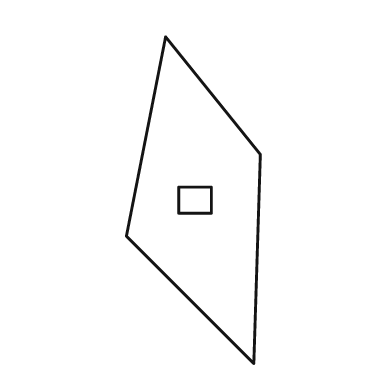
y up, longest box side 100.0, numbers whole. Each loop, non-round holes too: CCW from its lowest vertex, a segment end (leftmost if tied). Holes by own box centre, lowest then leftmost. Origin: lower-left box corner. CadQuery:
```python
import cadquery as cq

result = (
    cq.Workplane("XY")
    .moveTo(39.0, 0.0)
    .lineTo(41.0, 64.0)
    .lineTo(12.0, 100.0)
    .lineTo(0.0, 39.0)
    .close()
    .moveTo(16.0, 46.0)
    .lineTo(26.0, 46.0)
    .lineTo(26.0, 54.0)
    .lineTo(16.0, 54.0)
    .close()
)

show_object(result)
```